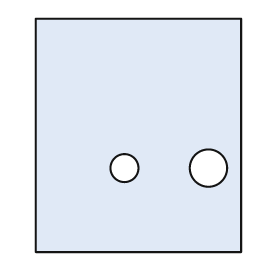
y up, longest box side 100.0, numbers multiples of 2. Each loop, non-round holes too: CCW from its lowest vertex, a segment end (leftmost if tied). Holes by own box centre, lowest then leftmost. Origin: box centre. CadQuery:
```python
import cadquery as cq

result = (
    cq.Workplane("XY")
    .moveTo(-44.0, -50.0)
    .lineTo(44.0, -50.0)
    .lineTo(44.0, 50.0)
    .lineTo(-44.0, 50.0)
    .close()
    .moveTo(-6.0, -14.0)
    .circle(6.0)
    .moveTo(30.0, -14.0)
    .circle(8.0)
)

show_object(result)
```